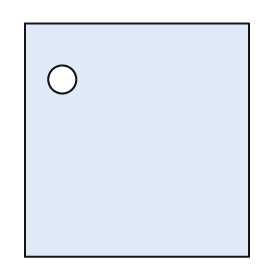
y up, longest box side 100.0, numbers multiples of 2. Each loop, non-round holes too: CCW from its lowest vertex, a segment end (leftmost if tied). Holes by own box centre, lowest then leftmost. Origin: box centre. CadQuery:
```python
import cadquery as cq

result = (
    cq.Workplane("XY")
    .moveTo(-48.0, -50.0)
    .lineTo(48.0, -50.0)
    .lineTo(48.0, 50.0)
    .lineTo(-48.0, 50.0)
    .close()
    .moveTo(-32.0, 26.0)
    .circle(6.0)
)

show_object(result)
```